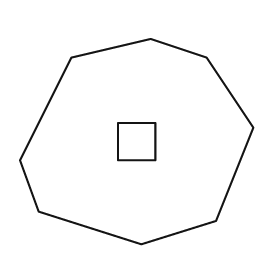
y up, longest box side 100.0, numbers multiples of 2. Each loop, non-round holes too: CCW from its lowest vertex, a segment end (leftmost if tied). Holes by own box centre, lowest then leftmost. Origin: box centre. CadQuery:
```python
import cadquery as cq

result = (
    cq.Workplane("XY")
    .moveTo(2.0, -44.0)
    .lineTo(34.0, -34.0)
    .lineTo(50.0, 6.0)
    .lineTo(30.0, 36.0)
    .lineTo(6.0, 44.0)
    .lineTo(-28.0, 36.0)
    .lineTo(-50.0, -8.0)
    .lineTo(-42.0, -30.0)
    .close()
    .moveTo(-8.0, -8.0)
    .lineTo(8.0, -8.0)
    .lineTo(8.0, 8.0)
    .lineTo(-8.0, 8.0)
    .close()
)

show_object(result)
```